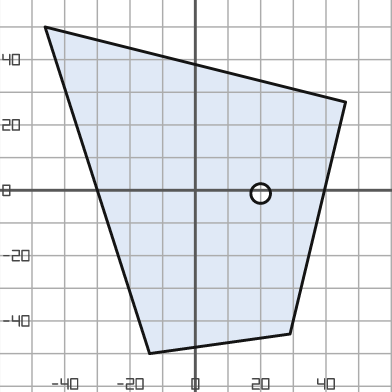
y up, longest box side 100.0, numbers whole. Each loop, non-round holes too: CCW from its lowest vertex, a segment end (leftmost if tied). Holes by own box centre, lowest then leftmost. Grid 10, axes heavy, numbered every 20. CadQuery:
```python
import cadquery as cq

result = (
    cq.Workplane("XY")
    .moveTo(-14.0, -50.0)
    .lineTo(29.0, -44.0)
    .lineTo(46.0, 27.0)
    .lineTo(-46.0, 50.0)
    .close()
    .moveTo(20.0, -1.0)
    .circle(3.0)
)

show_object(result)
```